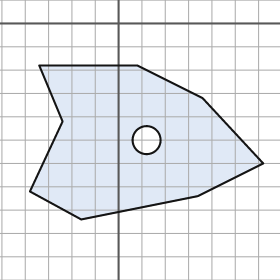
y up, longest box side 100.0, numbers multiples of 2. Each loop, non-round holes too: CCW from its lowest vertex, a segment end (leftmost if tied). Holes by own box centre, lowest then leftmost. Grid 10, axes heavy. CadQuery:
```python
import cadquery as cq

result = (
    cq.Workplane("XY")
    .moveTo(-16.0, -84.0)
    .lineTo(34.0, -74.0)
    .lineTo(62.0, -60.0)
    .lineTo(36.0, -32.0)
    .lineTo(8.0, -18.0)
    .lineTo(-34.0, -18.0)
    .lineTo(-24.0, -42.0)
    .lineTo(-38.0, -72.0)
    .close()
    .moveTo(12.0, -50.0)
    .circle(6.0)
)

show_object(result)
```